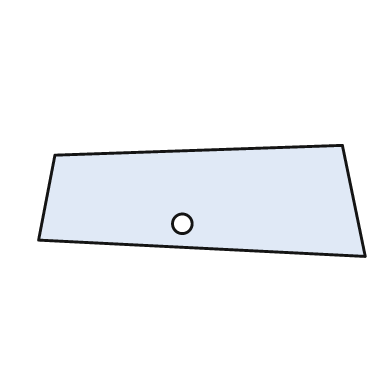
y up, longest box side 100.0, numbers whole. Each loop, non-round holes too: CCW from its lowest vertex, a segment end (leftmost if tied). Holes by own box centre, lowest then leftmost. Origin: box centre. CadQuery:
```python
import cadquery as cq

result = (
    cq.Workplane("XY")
    .moveTo(50.0, -17.0)
    .lineTo(43.0, 17.0)
    .lineTo(-45.0, 14.0)
    .lineTo(-50.0, -12.0)
    .close()
    .moveTo(-6.0, -7.0)
    .circle(3.0)
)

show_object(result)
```